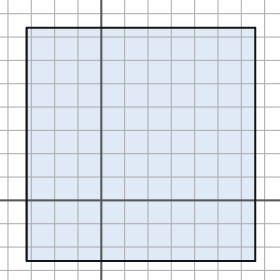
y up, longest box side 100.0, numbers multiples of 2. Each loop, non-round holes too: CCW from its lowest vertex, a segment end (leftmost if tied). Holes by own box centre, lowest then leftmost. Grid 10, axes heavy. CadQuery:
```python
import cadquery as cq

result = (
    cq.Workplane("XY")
    .moveTo(-32.0, -26.0)
    .lineTo(66.0, -26.0)
    .lineTo(66.0, 74.0)
    .lineTo(-32.0, 74.0)
    .close()
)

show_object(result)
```